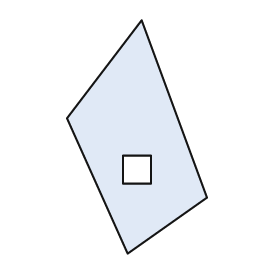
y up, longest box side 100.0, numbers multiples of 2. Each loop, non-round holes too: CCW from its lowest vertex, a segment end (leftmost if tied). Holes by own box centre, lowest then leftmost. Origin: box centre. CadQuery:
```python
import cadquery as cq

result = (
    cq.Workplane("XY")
    .moveTo(-4.0, -50.0)
    .lineTo(30.0, -26.0)
    .lineTo(2.0, 50.0)
    .lineTo(-30.0, 8.0)
    .close()
    .moveTo(-6.0, -20.0)
    .lineTo(6.0, -20.0)
    .lineTo(6.0, -8.0)
    .lineTo(-6.0, -8.0)
    .close()
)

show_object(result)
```